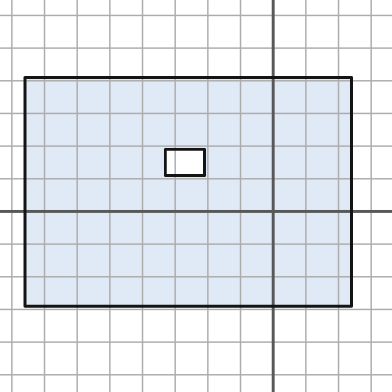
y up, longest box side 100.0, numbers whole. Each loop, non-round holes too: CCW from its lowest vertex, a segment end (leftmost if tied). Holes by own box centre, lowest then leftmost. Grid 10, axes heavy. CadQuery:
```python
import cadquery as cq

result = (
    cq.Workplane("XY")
    .moveTo(-76.0, -29.0)
    .lineTo(24.0, -29.0)
    .lineTo(24.0, 41.0)
    .lineTo(-76.0, 41.0)
    .close()
    .moveTo(-33.0, 11.0)
    .lineTo(-21.0, 11.0)
    .lineTo(-21.0, 19.0)
    .lineTo(-33.0, 19.0)
    .close()
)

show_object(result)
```